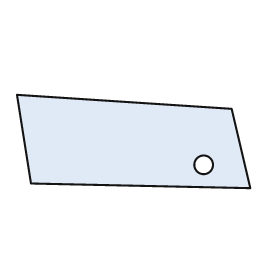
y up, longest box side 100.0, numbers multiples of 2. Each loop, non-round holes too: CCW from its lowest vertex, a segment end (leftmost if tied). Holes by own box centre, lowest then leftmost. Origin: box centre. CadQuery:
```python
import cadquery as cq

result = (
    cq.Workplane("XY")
    .moveTo(50.0, -20.0)
    .lineTo(42.0, 14.0)
    .lineTo(-50.0, 20.0)
    .lineTo(-44.0, -18.0)
    .close()
    .moveTo(30.0, -10.0)
    .circle(4.0)
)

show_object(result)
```